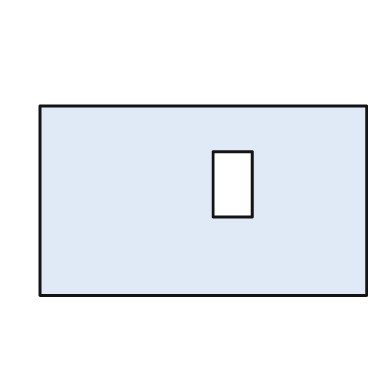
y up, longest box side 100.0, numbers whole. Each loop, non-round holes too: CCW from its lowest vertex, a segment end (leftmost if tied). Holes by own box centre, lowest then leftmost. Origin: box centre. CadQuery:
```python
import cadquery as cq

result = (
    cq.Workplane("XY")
    .moveTo(-50.0, -29.0)
    .lineTo(50.0, -29.0)
    .lineTo(50.0, 29.0)
    .lineTo(-50.0, 29.0)
    .close()
    .moveTo(3.0, -5.0)
    .lineTo(15.0, -5.0)
    .lineTo(15.0, 15.0)
    .lineTo(3.0, 15.0)
    .close()
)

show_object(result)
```